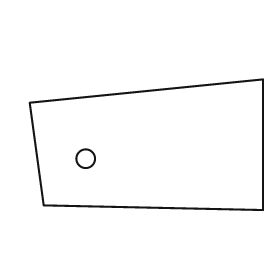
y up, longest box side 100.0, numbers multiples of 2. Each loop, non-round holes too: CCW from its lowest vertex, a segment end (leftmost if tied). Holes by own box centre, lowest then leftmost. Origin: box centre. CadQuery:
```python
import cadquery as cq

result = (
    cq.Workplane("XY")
    .moveTo(50.0, -28.0)
    .lineTo(50.0, 28.0)
    .lineTo(-50.0, 18.0)
    .lineTo(-44.0, -26.0)
    .close()
    .moveTo(-26.0, -6.0)
    .circle(4.0)
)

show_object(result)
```